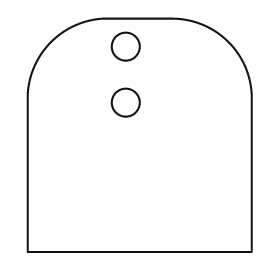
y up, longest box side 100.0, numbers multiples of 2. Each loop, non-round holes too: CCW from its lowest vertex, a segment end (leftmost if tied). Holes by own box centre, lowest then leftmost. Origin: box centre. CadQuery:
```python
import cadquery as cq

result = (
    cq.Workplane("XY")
    .moveTo(-48.0, -50.0)
    .lineTo(48.0, -50.0)
    .lineTo(48.0, 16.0)
    .threePointArc((38.0, 40.0), (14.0, 50.0))
    .lineTo(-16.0, 50.0)
    .threePointArc((-38.0, 40.0), (-48.0, 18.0))
    .close()
    .moveTo(-6.0, 14.0)
    .circle(6.0)
    .moveTo(-6.0, 38.0)
    .circle(6.0)
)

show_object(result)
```